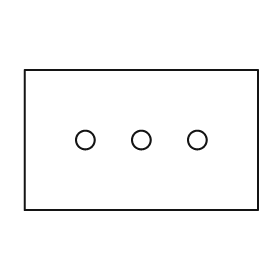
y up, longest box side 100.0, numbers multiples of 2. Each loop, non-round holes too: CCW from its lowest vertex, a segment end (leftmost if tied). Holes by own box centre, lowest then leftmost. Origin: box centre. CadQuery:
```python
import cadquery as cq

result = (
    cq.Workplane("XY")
    .moveTo(-50.0, -30.0)
    .lineTo(50.0, -30.0)
    .lineTo(50.0, 30.0)
    .lineTo(-50.0, 30.0)
    .close()
    .moveTo(-24.0, 0.0)
    .circle(4.0)
    .moveTo(0.0, 0.0)
    .circle(4.0)
    .moveTo(24.0, 0.0)
    .circle(4.0)
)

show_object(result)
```